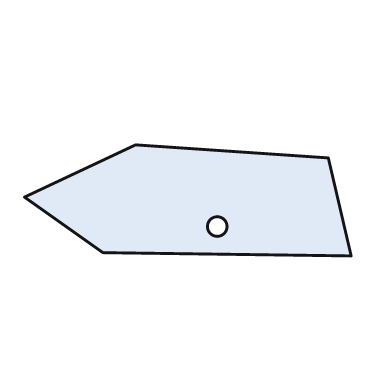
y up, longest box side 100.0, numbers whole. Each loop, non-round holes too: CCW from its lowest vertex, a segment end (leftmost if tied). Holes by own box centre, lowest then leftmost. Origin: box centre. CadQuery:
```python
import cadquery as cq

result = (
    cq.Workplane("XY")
    .moveTo(50.0, -17.0)
    .lineTo(43.0, 13.0)
    .lineTo(-16.0, 17.0)
    .lineTo(-50.0, 1.0)
    .lineTo(-26.0, -16.0)
    .close()
    .moveTo(9.0, -8.0)
    .circle(3.0)
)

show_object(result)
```